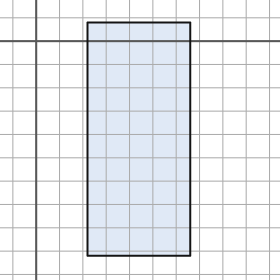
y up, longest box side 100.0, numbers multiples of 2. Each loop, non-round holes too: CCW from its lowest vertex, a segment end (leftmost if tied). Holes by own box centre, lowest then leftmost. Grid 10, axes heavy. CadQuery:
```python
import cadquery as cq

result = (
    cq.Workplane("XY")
    .moveTo(22.0, -92.0)
    .lineTo(66.0, -92.0)
    .lineTo(66.0, 8.0)
    .lineTo(22.0, 8.0)
    .close()
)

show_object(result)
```